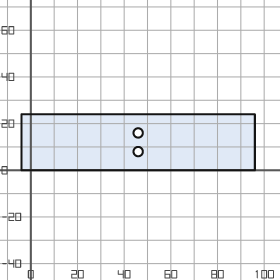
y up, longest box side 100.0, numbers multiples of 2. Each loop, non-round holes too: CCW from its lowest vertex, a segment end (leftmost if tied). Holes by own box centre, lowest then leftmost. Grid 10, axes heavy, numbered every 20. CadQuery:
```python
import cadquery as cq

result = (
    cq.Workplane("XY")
    .moveTo(-4.0, 0.0)
    .lineTo(96.0, 0.0)
    .lineTo(96.0, 24.0)
    .lineTo(-4.0, 24.0)
    .close()
    .moveTo(46.0, 8.0)
    .circle(2.0)
    .moveTo(46.0, 16.0)
    .circle(2.0)
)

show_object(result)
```